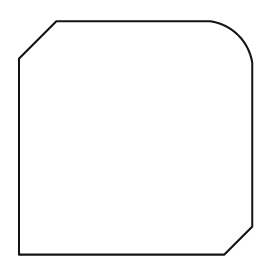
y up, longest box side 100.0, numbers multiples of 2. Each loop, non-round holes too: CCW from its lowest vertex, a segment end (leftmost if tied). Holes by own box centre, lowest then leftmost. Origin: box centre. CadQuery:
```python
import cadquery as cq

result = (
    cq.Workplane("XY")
    .moveTo(-50.0, -50.0)
    .lineTo(38.0, -50.0)
    .lineTo(50.0, -38.0)
    .lineTo(50.0, 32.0)
    .threePointArc((44.0, 44.0), (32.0, 50.0))
    .lineTo(-34.0, 50.0)
    .lineTo(-50.0, 34.0)
    .close()
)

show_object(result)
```